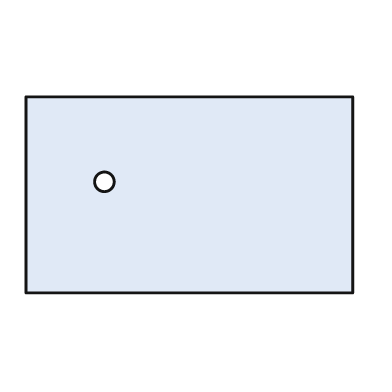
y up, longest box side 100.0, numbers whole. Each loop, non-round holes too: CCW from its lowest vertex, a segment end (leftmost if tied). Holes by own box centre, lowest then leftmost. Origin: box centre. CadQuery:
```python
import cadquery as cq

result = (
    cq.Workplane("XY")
    .moveTo(-50.0, -30.0)
    .lineTo(50.0, -30.0)
    .lineTo(50.0, 30.0)
    .lineTo(-50.0, 30.0)
    .close()
    .moveTo(-26.0, 4.0)
    .circle(3.0)
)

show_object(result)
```